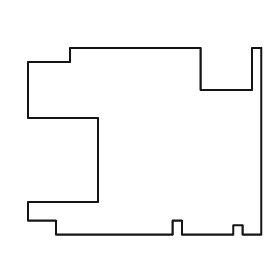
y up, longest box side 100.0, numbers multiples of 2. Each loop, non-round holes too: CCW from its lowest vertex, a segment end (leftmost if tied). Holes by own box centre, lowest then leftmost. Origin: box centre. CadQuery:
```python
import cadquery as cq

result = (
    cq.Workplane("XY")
    .moveTo(-38.0, -40.0)
    .lineTo(12.0, -40.0)
    .lineTo(12.0, -34.0)
    .lineTo(16.0, -34.0)
    .lineTo(16.0, -40.0)
    .lineTo(38.0, -40.0)
    .lineTo(38.0, -36.0)
    .lineTo(42.0, -36.0)
    .lineTo(42.0, -40.0)
    .lineTo(50.0, -40.0)
    .lineTo(50.0, 40.0)
    .lineTo(46.0, 40.0)
    .lineTo(46.0, 22.0)
    .lineTo(24.0, 22.0)
    .lineTo(24.0, 40.0)
    .lineTo(-32.0, 40.0)
    .lineTo(-32.0, 34.0)
    .lineTo(-50.0, 34.0)
    .lineTo(-50.0, 10.0)
    .lineTo(-20.0, 10.0)
    .lineTo(-20.0, -26.0)
    .lineTo(-50.0, -26.0)
    .lineTo(-50.0, -34.0)
    .lineTo(-38.0, -34.0)
    .close()
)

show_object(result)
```